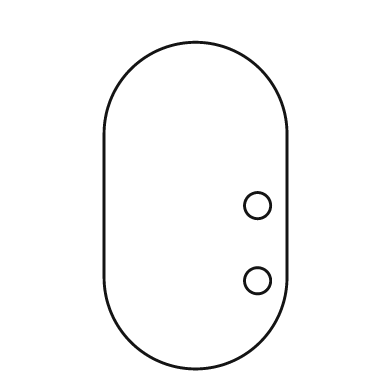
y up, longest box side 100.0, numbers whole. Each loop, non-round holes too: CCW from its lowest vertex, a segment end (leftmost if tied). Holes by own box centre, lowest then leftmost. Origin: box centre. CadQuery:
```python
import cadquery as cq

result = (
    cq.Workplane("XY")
    .moveTo(-28.0, -22.0)
    .threePointArc((0.0, -50.0), (28.0, -22.0))
    .lineTo(28.0, 22.0)
    .threePointArc((0.0, 50.0), (-28.0, 22.0))
    .close()
    .moveTo(19.0, -23.0)
    .circle(4.0)
    .moveTo(19.0, 0.0)
    .circle(4.0)
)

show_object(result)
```